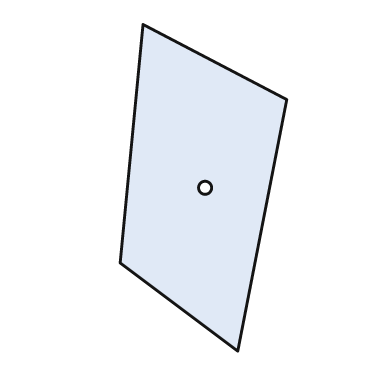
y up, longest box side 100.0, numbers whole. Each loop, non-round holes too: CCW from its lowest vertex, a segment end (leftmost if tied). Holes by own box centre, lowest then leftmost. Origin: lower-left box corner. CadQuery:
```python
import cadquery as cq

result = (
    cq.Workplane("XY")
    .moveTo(36.0, 0.0)
    .lineTo(51.0, 77.0)
    .lineTo(7.0, 100.0)
    .lineTo(0.0, 27.0)
    .close()
    .moveTo(26.0, 50.0)
    .circle(2.0)
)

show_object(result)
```